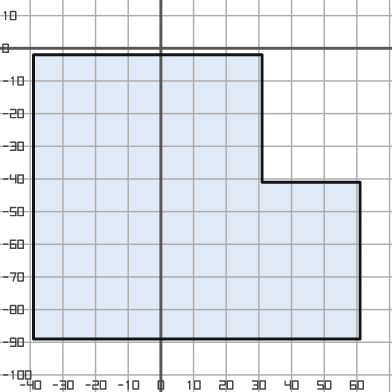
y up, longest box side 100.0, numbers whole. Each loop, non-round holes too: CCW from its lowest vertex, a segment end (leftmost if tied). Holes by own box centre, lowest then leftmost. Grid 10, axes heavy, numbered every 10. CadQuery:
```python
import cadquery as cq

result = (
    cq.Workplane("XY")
    .moveTo(-39.0, -89.0)
    .lineTo(61.0, -89.0)
    .lineTo(61.0, -41.0)
    .lineTo(31.0, -41.0)
    .lineTo(31.0, -2.0)
    .lineTo(-39.0, -2.0)
    .close()
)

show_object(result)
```